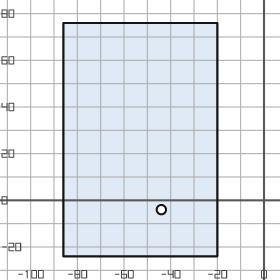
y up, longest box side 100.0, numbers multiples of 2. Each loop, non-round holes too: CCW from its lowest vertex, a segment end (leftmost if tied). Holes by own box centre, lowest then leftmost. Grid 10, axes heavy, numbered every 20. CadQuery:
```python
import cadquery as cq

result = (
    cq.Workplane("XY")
    .moveTo(-86.0, -24.0)
    .lineTo(-20.0, -24.0)
    .lineTo(-20.0, 76.0)
    .lineTo(-86.0, 76.0)
    .close()
    .moveTo(-44.0, -4.0)
    .circle(2.0)
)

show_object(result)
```